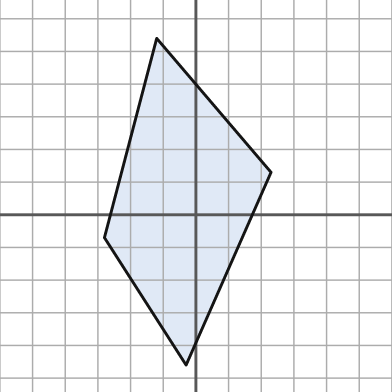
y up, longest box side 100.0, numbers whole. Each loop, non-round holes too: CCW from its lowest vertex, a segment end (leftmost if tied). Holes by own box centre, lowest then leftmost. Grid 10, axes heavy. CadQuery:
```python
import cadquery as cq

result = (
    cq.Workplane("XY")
    .moveTo(-3.0, -46.0)
    .lineTo(23.0, 13.0)
    .lineTo(-12.0, 54.0)
    .lineTo(-28.0, -7.0)
    .close()
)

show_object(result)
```